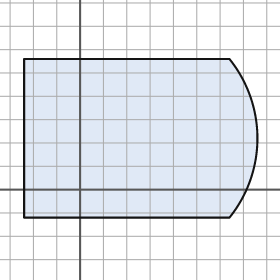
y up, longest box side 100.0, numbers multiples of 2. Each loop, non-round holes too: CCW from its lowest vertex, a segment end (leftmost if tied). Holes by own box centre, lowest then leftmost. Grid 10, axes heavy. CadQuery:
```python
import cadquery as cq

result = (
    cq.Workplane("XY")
    .moveTo(-24.0, -12.0)
    .lineTo(64.0, -12.0)
    .threePointArc((76.0, 22.0), (64.0, 56.0))
    .lineTo(-24.0, 56.0)
    .close()
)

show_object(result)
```